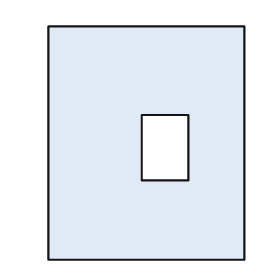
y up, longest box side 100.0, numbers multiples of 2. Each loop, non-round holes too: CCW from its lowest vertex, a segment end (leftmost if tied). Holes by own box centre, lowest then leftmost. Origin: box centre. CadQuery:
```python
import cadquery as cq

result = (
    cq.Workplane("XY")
    .moveTo(-42.0, -50.0)
    .lineTo(42.0, -50.0)
    .lineTo(42.0, 50.0)
    .lineTo(-42.0, 50.0)
    .close()
    .moveTo(-2.0, -16.0)
    .lineTo(18.0, -16.0)
    .lineTo(18.0, 12.0)
    .lineTo(-2.0, 12.0)
    .close()
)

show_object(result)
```